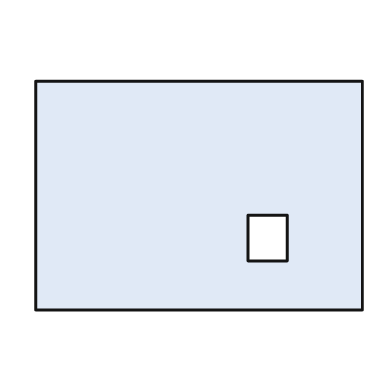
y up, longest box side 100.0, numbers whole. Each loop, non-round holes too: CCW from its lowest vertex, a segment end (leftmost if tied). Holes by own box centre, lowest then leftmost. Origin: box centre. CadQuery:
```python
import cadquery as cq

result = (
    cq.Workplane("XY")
    .moveTo(-50.0, -35.0)
    .lineTo(50.0, -35.0)
    .lineTo(50.0, 35.0)
    .lineTo(-50.0, 35.0)
    .close()
    .moveTo(15.0, -20.0)
    .lineTo(27.0, -20.0)
    .lineTo(27.0, -6.0)
    .lineTo(15.0, -6.0)
    .close()
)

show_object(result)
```